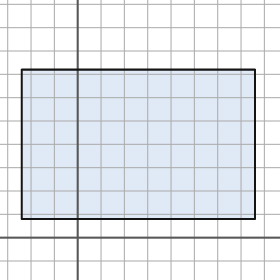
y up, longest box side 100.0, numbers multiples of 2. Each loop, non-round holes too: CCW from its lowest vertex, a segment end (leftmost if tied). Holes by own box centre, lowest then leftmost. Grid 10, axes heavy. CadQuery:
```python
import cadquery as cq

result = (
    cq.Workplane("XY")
    .moveTo(-24.0, 8.0)
    .lineTo(76.0, 8.0)
    .lineTo(76.0, 72.0)
    .lineTo(-24.0, 72.0)
    .close()
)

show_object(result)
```